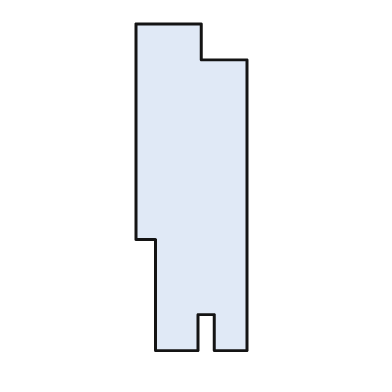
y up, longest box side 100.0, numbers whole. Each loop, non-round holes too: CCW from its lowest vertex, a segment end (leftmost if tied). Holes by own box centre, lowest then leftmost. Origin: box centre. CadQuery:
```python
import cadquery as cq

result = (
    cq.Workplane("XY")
    .moveTo(-11.0, -50.0)
    .lineTo(2.0, -50.0)
    .lineTo(2.0, -39.0)
    .lineTo(7.0, -39.0)
    .lineTo(7.0, -50.0)
    .lineTo(17.0, -50.0)
    .lineTo(17.0, 39.0)
    .lineTo(3.0, 39.0)
    .lineTo(3.0, 50.0)
    .lineTo(-17.0, 50.0)
    .lineTo(-17.0, -16.0)
    .lineTo(-11.0, -16.0)
    .close()
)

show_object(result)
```